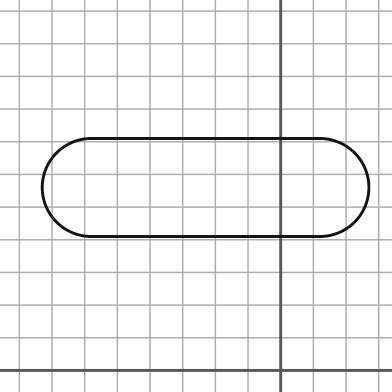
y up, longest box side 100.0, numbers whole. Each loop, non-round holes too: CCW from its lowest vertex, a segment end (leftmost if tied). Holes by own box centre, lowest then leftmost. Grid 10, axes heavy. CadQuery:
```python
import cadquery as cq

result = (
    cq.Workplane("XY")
    .moveTo(-58.0, 41.0)
    .lineTo(12.0, 41.0)
    .threePointArc((27.0, 56.0), (12.0, 71.0))
    .lineTo(-58.0, 71.0)
    .threePointArc((-73.0, 56.0), (-58.0, 41.0))
    .close()
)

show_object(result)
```